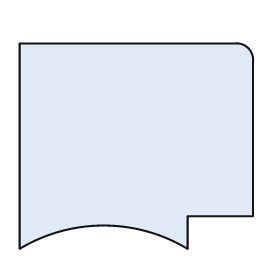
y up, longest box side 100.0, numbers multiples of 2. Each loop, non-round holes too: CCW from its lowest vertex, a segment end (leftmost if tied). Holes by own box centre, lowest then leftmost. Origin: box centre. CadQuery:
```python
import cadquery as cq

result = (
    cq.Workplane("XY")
    .moveTo(-50.0, -44.0)
    .threePointArc((-14.0, -34.0), (22.0, -44.0))
    .lineTo(22.0, -30.0)
    .lineTo(50.0, -30.0)
    .lineTo(50.0, 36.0)
    .threePointArc((48.0, 42.0), (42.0, 44.0))
    .lineTo(-50.0, 44.0)
    .close()
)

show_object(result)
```